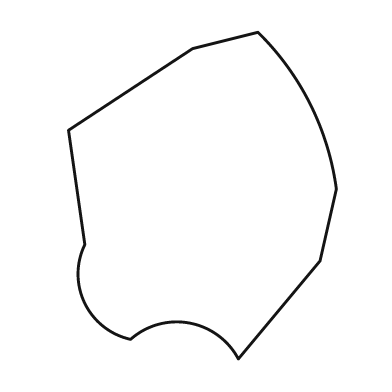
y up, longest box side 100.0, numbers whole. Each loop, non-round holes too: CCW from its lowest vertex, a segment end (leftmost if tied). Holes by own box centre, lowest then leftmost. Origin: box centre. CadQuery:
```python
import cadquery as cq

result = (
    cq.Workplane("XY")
    .moveTo(11.0, -50.0)
    .lineTo(36.0, -20.0)
    .lineTo(41.0, 2.0)
    .threePointArc((33.0, 28.0), (17.0, 50.0))
    .lineTo(-3.0, 45.0)
    .lineTo(-41.0, 20.0)
    .lineTo(-36.0, -15.0)
    .threePointArc((-36.0, -33.0), (-22.0, -44.0))
    .threePointArc((-4.0, -39.0), (11.0, -50.0))
    .close()
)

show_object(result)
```